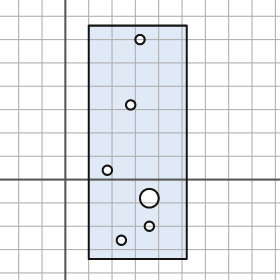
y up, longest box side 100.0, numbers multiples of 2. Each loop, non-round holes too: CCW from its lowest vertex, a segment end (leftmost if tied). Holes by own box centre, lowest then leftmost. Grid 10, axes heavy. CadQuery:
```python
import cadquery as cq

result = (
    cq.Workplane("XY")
    .moveTo(10.0, -34.0)
    .lineTo(52.0, -34.0)
    .lineTo(52.0, 66.0)
    .lineTo(10.0, 66.0)
    .close()
    .moveTo(24.0, -26.0)
    .circle(2.0)
    .moveTo(36.0, -20.0)
    .circle(2.0)
    .moveTo(36.0, -8.0)
    .circle(4.0)
    .moveTo(18.0, 4.0)
    .circle(2.0)
    .moveTo(28.0, 32.0)
    .circle(2.0)
    .moveTo(32.0, 60.0)
    .circle(2.0)
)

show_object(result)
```